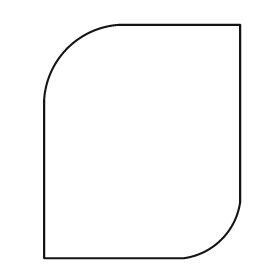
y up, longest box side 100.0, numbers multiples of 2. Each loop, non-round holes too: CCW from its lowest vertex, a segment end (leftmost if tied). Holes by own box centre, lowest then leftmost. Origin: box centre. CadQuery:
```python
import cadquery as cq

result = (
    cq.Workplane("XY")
    .moveTo(-42.0, -50.0)
    .lineTo(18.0, -50.0)
    .threePointArc((34.0, -42.0), (42.0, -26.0))
    .lineTo(42.0, 50.0)
    .lineTo(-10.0, 50.0)
    .threePointArc((-32.0, 40.0), (-42.0, 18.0))
    .close()
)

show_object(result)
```